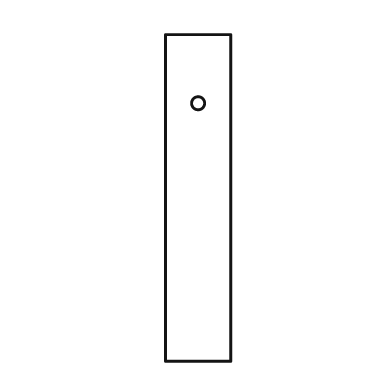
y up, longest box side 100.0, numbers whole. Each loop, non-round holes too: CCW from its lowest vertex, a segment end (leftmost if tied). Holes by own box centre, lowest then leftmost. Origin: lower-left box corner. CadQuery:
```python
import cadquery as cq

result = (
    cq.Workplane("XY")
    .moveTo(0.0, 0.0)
    .lineTo(20.0, 0.0)
    .lineTo(20.0, 100.0)
    .lineTo(0.0, 100.0)
    .close()
    .moveTo(10.0, 79.0)
    .circle(2.0)
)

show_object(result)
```